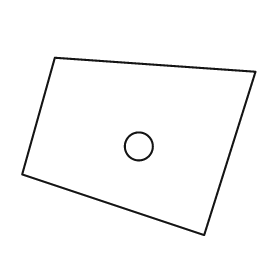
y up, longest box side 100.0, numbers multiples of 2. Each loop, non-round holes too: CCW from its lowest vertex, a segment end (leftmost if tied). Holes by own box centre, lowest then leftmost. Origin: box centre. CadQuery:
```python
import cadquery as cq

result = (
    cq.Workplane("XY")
    .moveTo(28.0, -38.0)
    .lineTo(50.0, 32.0)
    .lineTo(-36.0, 38.0)
    .lineTo(-50.0, -12.0)
    .close()
    .moveTo(0.0, 0.0)
    .circle(6.0)
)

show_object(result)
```